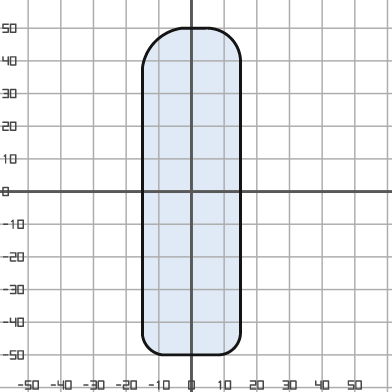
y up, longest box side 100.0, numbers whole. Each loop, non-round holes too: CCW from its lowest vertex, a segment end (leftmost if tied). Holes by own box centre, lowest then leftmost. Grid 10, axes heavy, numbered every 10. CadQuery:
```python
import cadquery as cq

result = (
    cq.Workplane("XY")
    .moveTo(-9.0, -50.0)
    .lineTo(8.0, -50.0)
    .threePointArc((13.0, -48.0), (15.0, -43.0))
    .lineTo(15.0, 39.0)
    .threePointArc((12.0, 47.0), (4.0, 50.0))
    .lineTo(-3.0, 50.0)
    .threePointArc((-11.0, 46.0), (-15.0, 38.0))
    .lineTo(-15.0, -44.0)
    .threePointArc((-13.0, -48.0), (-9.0, -50.0))
    .close()
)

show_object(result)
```